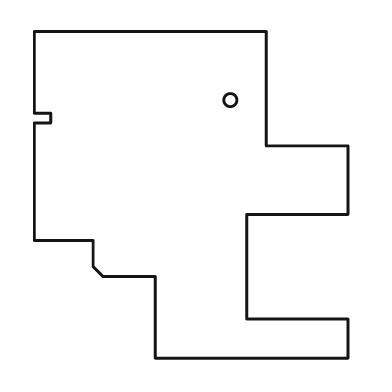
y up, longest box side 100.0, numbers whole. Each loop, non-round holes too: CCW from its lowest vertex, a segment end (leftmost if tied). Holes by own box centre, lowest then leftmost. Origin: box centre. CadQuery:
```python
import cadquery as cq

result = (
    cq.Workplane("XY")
    .moveTo(-11.0, -50.0)
    .lineTo(48.0, -50.0)
    .lineTo(48.0, -38.0)
    .lineTo(17.0, -38.0)
    .lineTo(17.0, -6.0)
    .lineTo(48.0, -6.0)
    .lineTo(48.0, 15.0)
    .lineTo(23.0, 15.0)
    .lineTo(23.0, 50.0)
    .lineTo(-48.0, 50.0)
    .lineTo(-48.0, 25.0)
    .lineTo(-43.0, 25.0)
    .lineTo(-43.0, 22.0)
    .lineTo(-48.0, 22.0)
    .lineTo(-48.0, -14.0)
    .lineTo(-30.0, -14.0)
    .lineTo(-30.0, -22.0)
    .lineTo(-27.0, -25.0)
    .lineTo(-11.0, -25.0)
    .close()
    .moveTo(12.0, 29.0)
    .circle(2.0)
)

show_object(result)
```